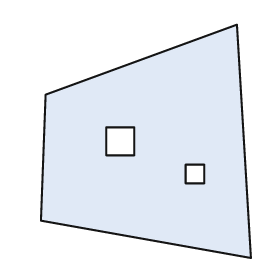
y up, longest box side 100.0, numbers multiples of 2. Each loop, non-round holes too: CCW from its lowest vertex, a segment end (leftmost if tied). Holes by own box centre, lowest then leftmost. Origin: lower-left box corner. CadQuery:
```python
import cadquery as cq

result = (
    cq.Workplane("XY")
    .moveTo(90.0, 0.0)
    .lineTo(84.0, 100.0)
    .lineTo(2.0, 70.0)
    .lineTo(0.0, 16.0)
    .close()
    .moveTo(62.0, 32.0)
    .lineTo(70.0, 32.0)
    .lineTo(70.0, 40.0)
    .lineTo(62.0, 40.0)
    .close()
    .moveTo(28.0, 44.0)
    .lineTo(40.0, 44.0)
    .lineTo(40.0, 56.0)
    .lineTo(28.0, 56.0)
    .close()
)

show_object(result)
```